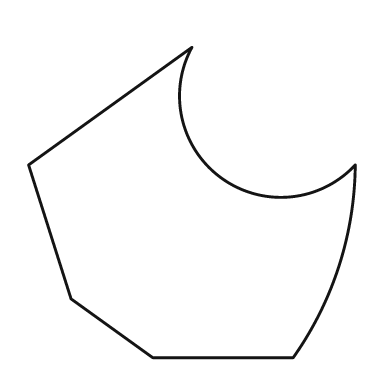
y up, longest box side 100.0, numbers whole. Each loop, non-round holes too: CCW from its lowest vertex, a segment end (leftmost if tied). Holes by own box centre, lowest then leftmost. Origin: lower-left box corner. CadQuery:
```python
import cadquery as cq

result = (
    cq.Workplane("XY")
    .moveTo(38.0, 0.0)
    .lineTo(81.0, 0.0)
    .threePointArc((95.0, 28.0), (100.0, 59.0))
    .threePointArc((59.0, 55.0), (50.0, 95.0))
    .lineTo(0.0, 59.0)
    .lineTo(13.0, 18.0)
    .close()
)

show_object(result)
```